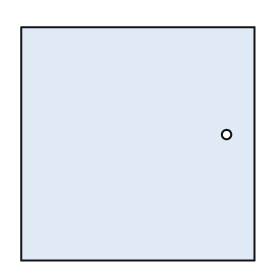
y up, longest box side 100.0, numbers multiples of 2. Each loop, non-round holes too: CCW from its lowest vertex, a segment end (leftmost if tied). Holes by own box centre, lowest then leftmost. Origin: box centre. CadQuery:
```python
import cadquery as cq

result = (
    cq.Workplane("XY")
    .moveTo(-50.0, -50.0)
    .lineTo(50.0, -50.0)
    .lineTo(50.0, 50.0)
    .lineTo(-50.0, 50.0)
    .close()
    .moveTo(38.0, 4.0)
    .circle(2.0)
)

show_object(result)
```